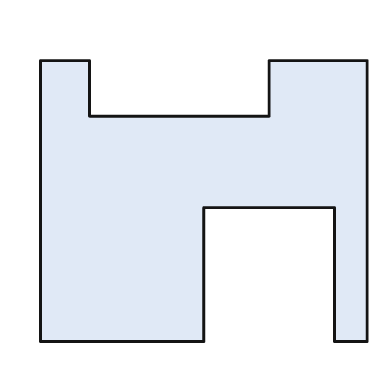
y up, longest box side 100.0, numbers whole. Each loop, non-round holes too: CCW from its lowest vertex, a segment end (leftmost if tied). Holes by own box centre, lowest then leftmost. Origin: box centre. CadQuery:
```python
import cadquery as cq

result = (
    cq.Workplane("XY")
    .moveTo(-50.0, -43.0)
    .lineTo(0.0, -43.0)
    .lineTo(0.0, -2.0)
    .lineTo(40.0, -2.0)
    .lineTo(40.0, -43.0)
    .lineTo(50.0, -43.0)
    .lineTo(50.0, 43.0)
    .lineTo(20.0, 43.0)
    .lineTo(20.0, 26.0)
    .lineTo(-35.0, 26.0)
    .lineTo(-35.0, 43.0)
    .lineTo(-50.0, 43.0)
    .close()
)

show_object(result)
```